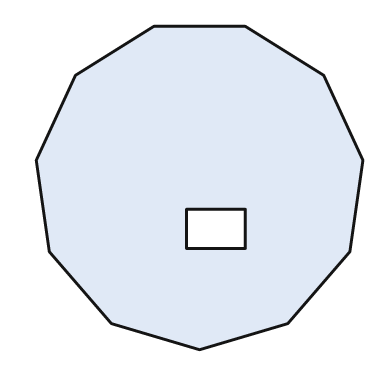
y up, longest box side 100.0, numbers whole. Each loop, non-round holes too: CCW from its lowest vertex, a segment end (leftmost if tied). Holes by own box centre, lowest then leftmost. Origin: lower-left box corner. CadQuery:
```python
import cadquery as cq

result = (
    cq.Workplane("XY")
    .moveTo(50.0, 0.0)
    .lineTo(77.0, 8.0)
    .lineTo(96.0, 30.0)
    .lineTo(100.0, 58.0)
    .lineTo(88.0, 84.0)
    .lineTo(64.0, 99.0)
    .lineTo(36.0, 99.0)
    .lineTo(12.0, 84.0)
    .lineTo(0.0, 58.0)
    .lineTo(4.0, 30.0)
    .lineTo(23.0, 8.0)
    .close()
    .moveTo(46.0, 31.0)
    .lineTo(64.0, 31.0)
    .lineTo(64.0, 43.0)
    .lineTo(46.0, 43.0)
    .close()
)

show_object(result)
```